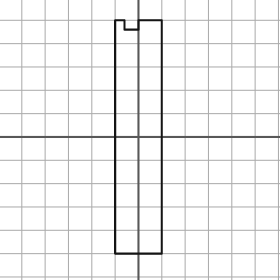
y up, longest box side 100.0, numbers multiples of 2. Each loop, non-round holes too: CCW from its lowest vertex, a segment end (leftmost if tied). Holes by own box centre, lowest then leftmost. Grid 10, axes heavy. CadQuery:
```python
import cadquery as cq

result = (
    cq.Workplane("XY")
    .moveTo(-10.0, -50.0)
    .lineTo(10.0, -50.0)
    .lineTo(10.0, 50.0)
    .lineTo(0.0, 50.0)
    .lineTo(0.0, 46.0)
    .lineTo(-6.0, 46.0)
    .lineTo(-6.0, 50.0)
    .lineTo(-10.0, 50.0)
    .close()
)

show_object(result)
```